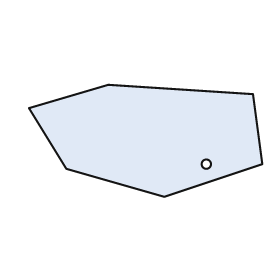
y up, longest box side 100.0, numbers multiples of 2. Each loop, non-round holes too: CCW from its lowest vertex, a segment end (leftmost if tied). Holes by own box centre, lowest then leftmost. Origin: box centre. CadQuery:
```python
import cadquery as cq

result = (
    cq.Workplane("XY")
    .moveTo(8.0, -24.0)
    .lineTo(50.0, -10.0)
    .lineTo(46.0, 20.0)
    .lineTo(-16.0, 24.0)
    .lineTo(-50.0, 14.0)
    .lineTo(-34.0, -12.0)
    .close()
    .moveTo(26.0, -10.0)
    .circle(2.0)
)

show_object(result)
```